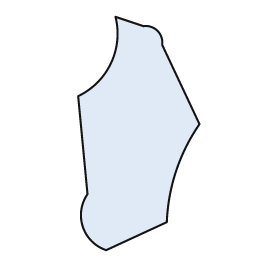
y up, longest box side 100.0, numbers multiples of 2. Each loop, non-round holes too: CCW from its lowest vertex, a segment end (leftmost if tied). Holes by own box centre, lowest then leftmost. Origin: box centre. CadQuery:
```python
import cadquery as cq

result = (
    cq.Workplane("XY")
    .moveTo(-14.0, -50.0)
    .lineTo(12.0, -38.0)
    .threePointArc((16.0, -16.0), (26.0, 4.0))
    .lineTo(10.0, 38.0)
    .threePointArc((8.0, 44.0), (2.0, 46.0))
    .lineTo(-10.0, 50.0)
    .threePointArc((-12.0, 30.0), (-26.0, 16.0))
    .lineTo(-22.0, -26.0)
    .threePointArc((-24.0, -40.0), (-14.0, -50.0))
    .close()
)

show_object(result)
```